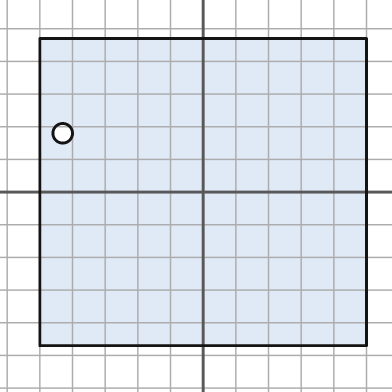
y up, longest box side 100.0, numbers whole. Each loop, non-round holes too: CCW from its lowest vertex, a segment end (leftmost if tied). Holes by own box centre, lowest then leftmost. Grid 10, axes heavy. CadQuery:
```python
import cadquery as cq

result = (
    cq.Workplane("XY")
    .moveTo(-50.0, -47.0)
    .lineTo(50.0, -47.0)
    .lineTo(50.0, 47.0)
    .lineTo(-50.0, 47.0)
    .close()
    .moveTo(-43.0, 18.0)
    .circle(3.0)
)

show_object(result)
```